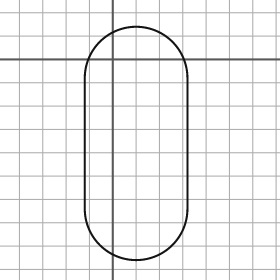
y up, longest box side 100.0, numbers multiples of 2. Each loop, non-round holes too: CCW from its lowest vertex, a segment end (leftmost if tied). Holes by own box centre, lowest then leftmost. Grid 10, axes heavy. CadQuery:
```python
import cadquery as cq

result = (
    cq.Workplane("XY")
    .moveTo(-12.0, -64.0)
    .threePointArc((10.0, -86.0), (32.0, -64.0))
    .lineTo(32.0, -8.0)
    .threePointArc((10.0, 14.0), (-12.0, -8.0))
    .close()
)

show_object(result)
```